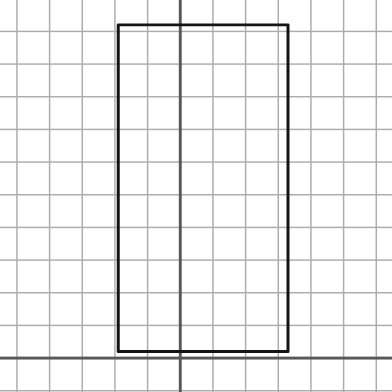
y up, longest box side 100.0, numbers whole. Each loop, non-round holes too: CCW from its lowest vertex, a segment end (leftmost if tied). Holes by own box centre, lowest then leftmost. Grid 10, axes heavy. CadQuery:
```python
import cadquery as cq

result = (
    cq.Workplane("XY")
    .moveTo(-19.0, 2.0)
    .lineTo(33.0, 2.0)
    .lineTo(33.0, 102.0)
    .lineTo(-19.0, 102.0)
    .close()
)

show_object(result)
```